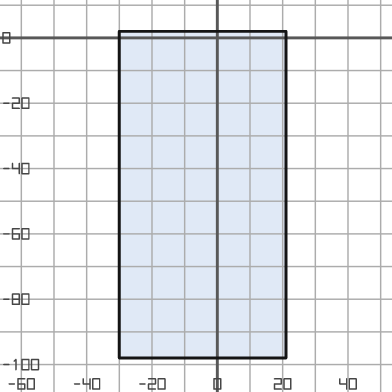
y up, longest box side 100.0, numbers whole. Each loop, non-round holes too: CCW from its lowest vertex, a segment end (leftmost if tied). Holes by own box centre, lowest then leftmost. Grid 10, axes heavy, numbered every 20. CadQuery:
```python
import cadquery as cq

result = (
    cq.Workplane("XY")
    .moveTo(-30.0, -98.0)
    .lineTo(21.0, -98.0)
    .lineTo(21.0, 2.0)
    .lineTo(-30.0, 2.0)
    .close()
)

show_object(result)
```